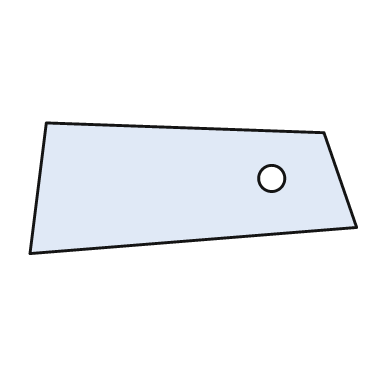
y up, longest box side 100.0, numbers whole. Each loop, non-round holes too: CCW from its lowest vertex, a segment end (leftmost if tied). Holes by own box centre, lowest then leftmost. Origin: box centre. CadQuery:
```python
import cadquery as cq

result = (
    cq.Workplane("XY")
    .moveTo(-50.0, -20.0)
    .lineTo(50.0, -12.0)
    .lineTo(40.0, 17.0)
    .lineTo(-45.0, 20.0)
    .close()
    .moveTo(24.0, 3.0)
    .circle(4.0)
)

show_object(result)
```